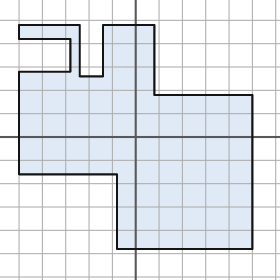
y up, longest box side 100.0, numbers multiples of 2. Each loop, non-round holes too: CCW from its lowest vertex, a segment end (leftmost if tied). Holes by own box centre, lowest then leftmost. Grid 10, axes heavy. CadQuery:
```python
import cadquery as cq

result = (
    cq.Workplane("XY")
    .moveTo(-8.0, -48.0)
    .lineTo(50.0, -48.0)
    .lineTo(50.0, 18.0)
    .lineTo(8.0, 18.0)
    .lineTo(8.0, 48.0)
    .lineTo(-14.0, 48.0)
    .lineTo(-14.0, 26.0)
    .lineTo(-24.0, 26.0)
    .lineTo(-24.0, 48.0)
    .lineTo(-50.0, 48.0)
    .lineTo(-50.0, 42.0)
    .lineTo(-28.0, 42.0)
    .lineTo(-28.0, 28.0)
    .lineTo(-50.0, 28.0)
    .lineTo(-50.0, -16.0)
    .lineTo(-8.0, -16.0)
    .close()
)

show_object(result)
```